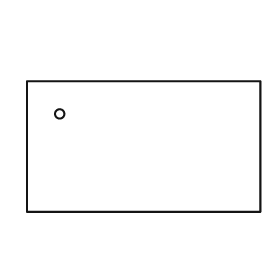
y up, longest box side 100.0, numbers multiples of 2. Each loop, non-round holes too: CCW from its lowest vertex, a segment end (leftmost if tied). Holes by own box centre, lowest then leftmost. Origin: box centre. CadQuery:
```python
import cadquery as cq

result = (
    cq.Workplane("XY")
    .moveTo(-50.0, -28.0)
    .lineTo(50.0, -28.0)
    .lineTo(50.0, 28.0)
    .lineTo(-50.0, 28.0)
    .close()
    .moveTo(-36.0, 14.0)
    .circle(2.0)
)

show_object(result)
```